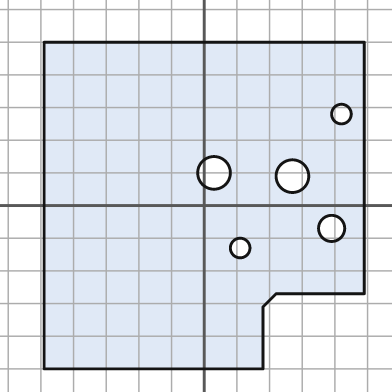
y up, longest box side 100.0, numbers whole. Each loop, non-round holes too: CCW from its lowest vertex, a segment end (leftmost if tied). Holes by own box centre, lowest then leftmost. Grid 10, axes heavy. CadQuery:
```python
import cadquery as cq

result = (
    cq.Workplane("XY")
    .moveTo(-49.0, -50.0)
    .lineTo(18.0, -50.0)
    .lineTo(18.0, -31.0)
    .lineTo(22.0, -27.0)
    .lineTo(49.0, -27.0)
    .lineTo(49.0, 50.0)
    .lineTo(-49.0, 50.0)
    .close()
    .moveTo(11.0, -13.0)
    .circle(3.0)
    .moveTo(39.0, -7.0)
    .circle(4.0)
    .moveTo(27.0, 9.0)
    .circle(5.0)
    .moveTo(3.0, 10.0)
    .circle(5.0)
    .moveTo(42.0, 28.0)
    .circle(3.0)
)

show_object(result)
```